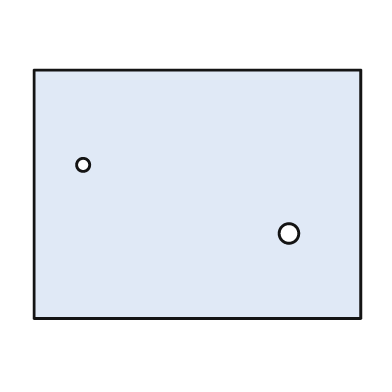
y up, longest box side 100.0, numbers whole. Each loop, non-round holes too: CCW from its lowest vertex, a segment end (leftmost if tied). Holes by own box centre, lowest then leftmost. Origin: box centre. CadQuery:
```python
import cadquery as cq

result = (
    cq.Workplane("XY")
    .moveTo(-50.0, -38.0)
    .lineTo(50.0, -38.0)
    .lineTo(50.0, 38.0)
    .lineTo(-50.0, 38.0)
    .close()
    .moveTo(28.0, -12.0)
    .circle(3.0)
    .moveTo(-35.0, 9.0)
    .circle(2.0)
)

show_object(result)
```